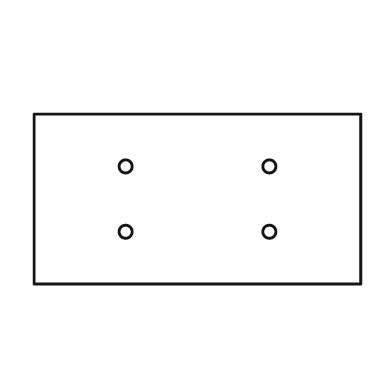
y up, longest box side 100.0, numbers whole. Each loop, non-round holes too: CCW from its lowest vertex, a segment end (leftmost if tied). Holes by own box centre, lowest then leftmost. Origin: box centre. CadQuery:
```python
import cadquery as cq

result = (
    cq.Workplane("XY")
    .moveTo(-50.0, -26.0)
    .lineTo(50.0, -26.0)
    .lineTo(50.0, 26.0)
    .lineTo(-50.0, 26.0)
    .close()
    .moveTo(-22.0, -10.0)
    .circle(2.0)
    .moveTo(22.0, -10.0)
    .circle(2.0)
    .moveTo(-22.0, 10.0)
    .circle(2.0)
    .moveTo(22.0, 10.0)
    .circle(2.0)
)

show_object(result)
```